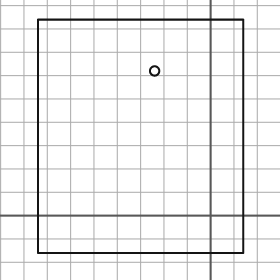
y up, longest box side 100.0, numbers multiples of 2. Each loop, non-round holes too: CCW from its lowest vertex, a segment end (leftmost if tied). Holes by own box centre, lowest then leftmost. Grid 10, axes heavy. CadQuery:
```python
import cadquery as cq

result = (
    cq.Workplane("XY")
    .moveTo(-74.0, -16.0)
    .lineTo(14.0, -16.0)
    .lineTo(14.0, 84.0)
    .lineTo(-74.0, 84.0)
    .close()
    .moveTo(-24.0, 62.0)
    .circle(2.0)
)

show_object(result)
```